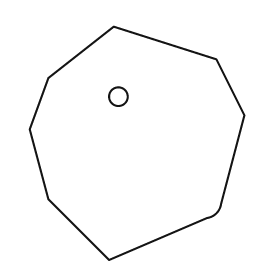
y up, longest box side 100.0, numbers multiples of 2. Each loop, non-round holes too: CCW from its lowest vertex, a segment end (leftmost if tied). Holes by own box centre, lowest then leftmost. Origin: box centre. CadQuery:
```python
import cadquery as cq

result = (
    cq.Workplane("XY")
    .moveTo(-12.0, -50.0)
    .lineTo(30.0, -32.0)
    .threePointArc((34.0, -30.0), (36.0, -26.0))
    .lineTo(46.0, 12.0)
    .lineTo(34.0, 36.0)
    .lineTo(-10.0, 50.0)
    .lineTo(-38.0, 28.0)
    .lineTo(-46.0, 6.0)
    .lineTo(-38.0, -24.0)
    .close()
    .moveTo(-8.0, 20.0)
    .circle(4.0)
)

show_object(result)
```